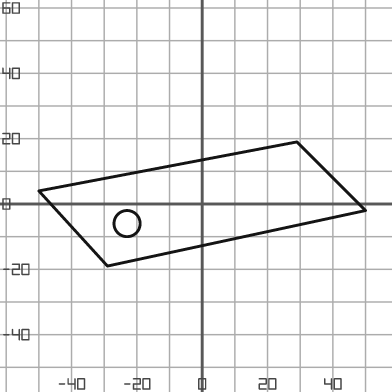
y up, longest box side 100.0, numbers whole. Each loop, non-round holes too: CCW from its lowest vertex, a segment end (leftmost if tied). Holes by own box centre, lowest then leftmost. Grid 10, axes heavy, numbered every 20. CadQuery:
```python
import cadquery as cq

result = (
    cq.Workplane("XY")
    .moveTo(-29.0, -19.0)
    .lineTo(50.0, -2.0)
    .lineTo(29.0, 19.0)
    .lineTo(-50.0, 4.0)
    .close()
    .moveTo(-23.0, -6.0)
    .circle(4.0)
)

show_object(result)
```